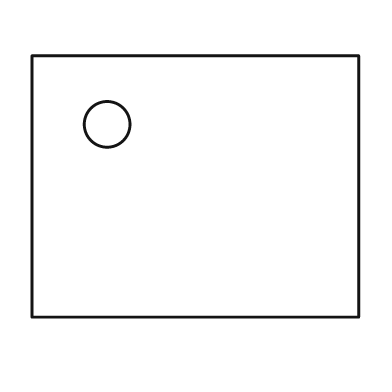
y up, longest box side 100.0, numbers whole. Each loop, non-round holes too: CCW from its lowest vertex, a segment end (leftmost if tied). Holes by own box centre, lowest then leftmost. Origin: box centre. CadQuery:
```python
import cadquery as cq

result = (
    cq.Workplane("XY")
    .moveTo(-50.0, -40.0)
    .lineTo(50.0, -40.0)
    .lineTo(50.0, 40.0)
    .lineTo(-50.0, 40.0)
    .close()
    .moveTo(-27.0, 19.0)
    .circle(7.0)
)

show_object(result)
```